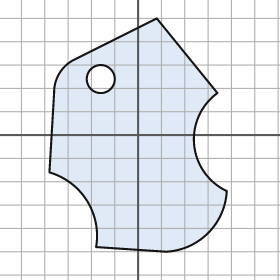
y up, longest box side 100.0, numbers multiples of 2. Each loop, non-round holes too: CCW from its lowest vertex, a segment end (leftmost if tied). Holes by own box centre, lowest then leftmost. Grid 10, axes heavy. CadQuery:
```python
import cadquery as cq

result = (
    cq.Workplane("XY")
    .moveTo(12.0, -50.0)
    .threePointArc((30.0, -42.0), (38.0, -24.0))
    .threePointArc((24.0, -4.0), (34.0, 18.0))
    .lineTo(8.0, 50.0)
    .lineTo(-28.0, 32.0)
    .threePointArc((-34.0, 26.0), (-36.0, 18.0))
    .lineTo(-38.0, -16.0)
    .threePointArc((-22.0, -28.0), (-18.0, -48.0))
    .close()
    .moveTo(-16.0, 24.0)
    .circle(6.0)
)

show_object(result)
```